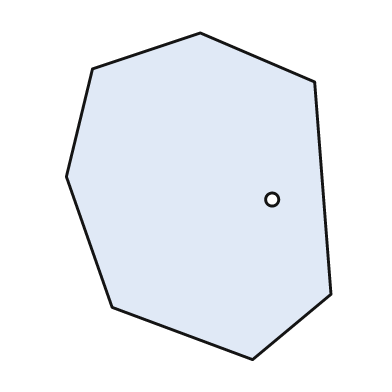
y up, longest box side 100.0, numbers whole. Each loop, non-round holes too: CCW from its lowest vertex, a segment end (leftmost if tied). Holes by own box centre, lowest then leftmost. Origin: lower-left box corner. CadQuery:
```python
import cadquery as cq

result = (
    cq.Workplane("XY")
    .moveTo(57.0, 0.0)
    .lineTo(81.0, 20.0)
    .lineTo(76.0, 85.0)
    .lineTo(41.0, 100.0)
    .lineTo(8.0, 89.0)
    .lineTo(0.0, 56.0)
    .lineTo(14.0, 16.0)
    .close()
    .moveTo(63.0, 49.0)
    .circle(2.0)
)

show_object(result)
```